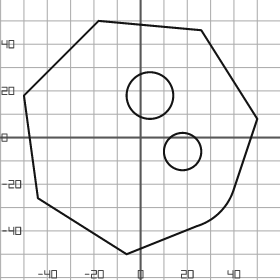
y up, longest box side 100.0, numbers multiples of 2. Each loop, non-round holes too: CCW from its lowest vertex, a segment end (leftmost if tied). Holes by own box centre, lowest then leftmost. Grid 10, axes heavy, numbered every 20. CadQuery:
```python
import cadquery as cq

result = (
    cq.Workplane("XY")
    .moveTo(-6.0, -50.0)
    .lineTo(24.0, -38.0)
    .threePointArc((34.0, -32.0), (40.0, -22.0))
    .lineTo(50.0, 8.0)
    .lineTo(26.0, 46.0)
    .lineTo(-18.0, 50.0)
    .lineTo(-50.0, 18.0)
    .lineTo(-44.0, -26.0)
    .close()
    .moveTo(18.0, -6.0)
    .circle(8.0)
    .moveTo(4.0, 18.0)
    .circle(10.0)
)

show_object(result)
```